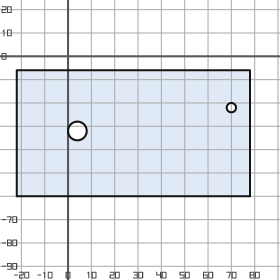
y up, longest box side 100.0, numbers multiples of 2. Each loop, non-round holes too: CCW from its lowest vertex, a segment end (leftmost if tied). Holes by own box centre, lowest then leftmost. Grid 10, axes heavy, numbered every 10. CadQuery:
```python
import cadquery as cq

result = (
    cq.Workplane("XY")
    .moveTo(-22.0, -60.0)
    .lineTo(78.0, -60.0)
    .lineTo(78.0, -6.0)
    .lineTo(-22.0, -6.0)
    .close()
    .moveTo(4.0, -32.0)
    .circle(4.0)
    .moveTo(70.0, -22.0)
    .circle(2.0)
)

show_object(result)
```